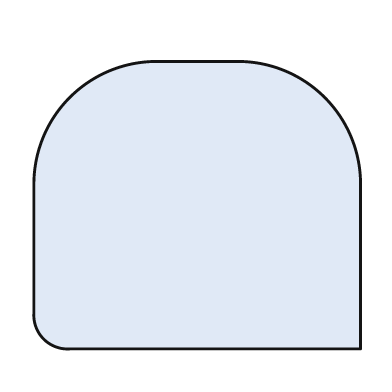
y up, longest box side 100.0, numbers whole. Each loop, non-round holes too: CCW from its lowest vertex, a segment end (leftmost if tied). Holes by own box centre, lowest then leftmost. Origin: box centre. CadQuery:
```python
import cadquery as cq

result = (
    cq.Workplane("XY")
    .moveTo(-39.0, -44.0)
    .lineTo(50.0, -44.0)
    .lineTo(50.0, 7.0)
    .threePointArc((39.0, 33.0), (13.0, 44.0))
    .lineTo(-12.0, 44.0)
    .threePointArc((-39.0, 33.0), (-50.0, 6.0))
    .lineTo(-50.0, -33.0)
    .threePointArc((-47.0, -41.0), (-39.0, -44.0))
    .close()
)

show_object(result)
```